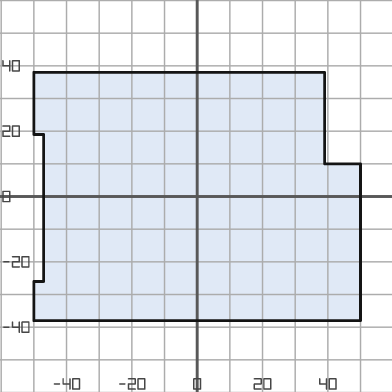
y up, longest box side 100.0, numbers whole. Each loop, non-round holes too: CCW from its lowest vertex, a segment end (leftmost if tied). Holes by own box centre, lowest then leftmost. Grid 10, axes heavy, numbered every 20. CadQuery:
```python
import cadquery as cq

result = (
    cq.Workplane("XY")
    .moveTo(-50.0, -38.0)
    .lineTo(50.0, -38.0)
    .lineTo(50.0, 10.0)
    .lineTo(39.0, 10.0)
    .lineTo(39.0, 38.0)
    .lineTo(-50.0, 38.0)
    .lineTo(-50.0, 19.0)
    .lineTo(-47.0, 19.0)
    .lineTo(-47.0, -26.0)
    .lineTo(-50.0, -26.0)
    .close()
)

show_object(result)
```